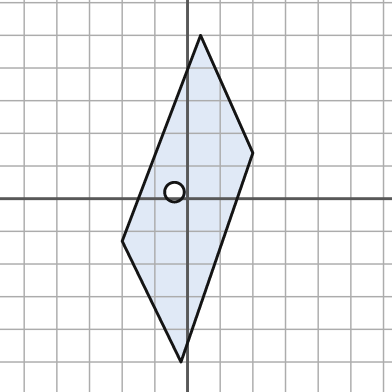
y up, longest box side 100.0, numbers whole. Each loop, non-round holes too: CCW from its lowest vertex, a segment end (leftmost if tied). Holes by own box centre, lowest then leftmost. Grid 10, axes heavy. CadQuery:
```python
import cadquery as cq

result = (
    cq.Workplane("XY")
    .moveTo(-2.0, -50.0)
    .lineTo(20.0, 14.0)
    .lineTo(4.0, 50.0)
    .lineTo(-20.0, -13.0)
    .close()
    .moveTo(-4.0, 2.0)
    .circle(3.0)
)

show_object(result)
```